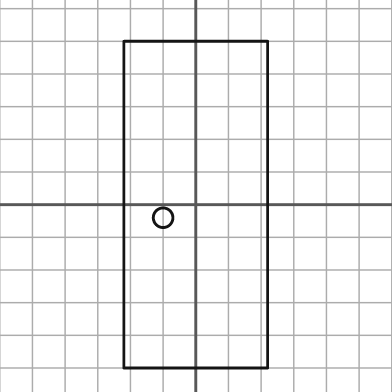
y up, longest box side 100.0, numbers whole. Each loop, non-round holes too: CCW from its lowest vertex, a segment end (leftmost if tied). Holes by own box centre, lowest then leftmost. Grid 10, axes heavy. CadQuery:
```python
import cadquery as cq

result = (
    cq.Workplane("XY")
    .moveTo(-22.0, -50.0)
    .lineTo(22.0, -50.0)
    .lineTo(22.0, 50.0)
    .lineTo(-22.0, 50.0)
    .close()
    .moveTo(-10.0, -4.0)
    .circle(3.0)
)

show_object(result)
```